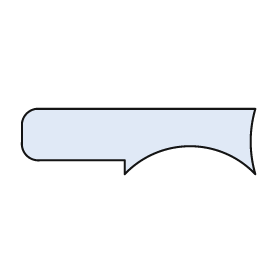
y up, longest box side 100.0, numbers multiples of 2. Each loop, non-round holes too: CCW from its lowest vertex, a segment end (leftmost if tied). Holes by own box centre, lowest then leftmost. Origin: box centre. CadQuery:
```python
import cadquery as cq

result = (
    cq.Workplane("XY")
    .moveTo(-6.0, -14.0)
    .threePointArc((22.0, -2.0), (50.0, -14.0))
    .threePointArc((48.0, 0.0), (50.0, 14.0))
    .lineTo(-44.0, 14.0)
    .threePointArc((-48.0, 12.0), (-50.0, 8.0))
    .lineTo(-50.0, 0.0)
    .threePointArc((-48.0, -6.0), (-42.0, -8.0))
    .lineTo(-6.0, -8.0)
    .close()
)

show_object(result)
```